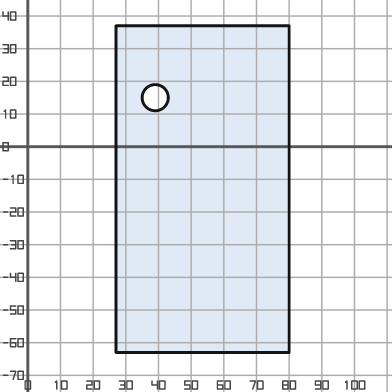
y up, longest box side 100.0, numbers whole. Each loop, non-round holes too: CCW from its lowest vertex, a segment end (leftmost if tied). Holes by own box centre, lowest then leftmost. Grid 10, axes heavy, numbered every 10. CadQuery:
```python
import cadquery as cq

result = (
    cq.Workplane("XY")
    .moveTo(27.0, -63.0)
    .lineTo(80.0, -63.0)
    .lineTo(80.0, 37.0)
    .lineTo(27.0, 37.0)
    .close()
    .moveTo(39.0, 15.0)
    .circle(4.0)
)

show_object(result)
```